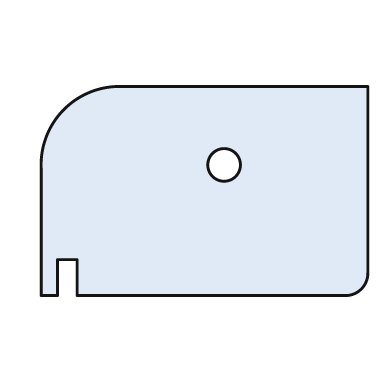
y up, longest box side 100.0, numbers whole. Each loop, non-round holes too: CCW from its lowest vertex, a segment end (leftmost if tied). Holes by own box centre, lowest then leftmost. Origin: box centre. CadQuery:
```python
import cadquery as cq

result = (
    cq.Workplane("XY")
    .moveTo(-50.0, -32.0)
    .lineTo(-45.0, -32.0)
    .lineTo(-45.0, -21.0)
    .lineTo(-39.0, -21.0)
    .lineTo(-39.0, -32.0)
    .lineTo(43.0, -32.0)
    .threePointArc((48.0, -30.0), (50.0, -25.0))
    .lineTo(50.0, 32.0)
    .lineTo(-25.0, 32.0)
    .threePointArc((-43.0, 25.0), (-50.0, 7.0))
    .close()
    .moveTo(6.0, 8.0)
    .circle(5.0)
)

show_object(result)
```